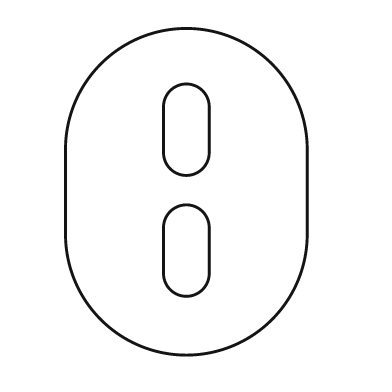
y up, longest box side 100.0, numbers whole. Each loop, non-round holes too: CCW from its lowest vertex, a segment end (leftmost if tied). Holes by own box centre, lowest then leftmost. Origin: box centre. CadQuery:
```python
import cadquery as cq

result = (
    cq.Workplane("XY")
    .moveTo(-37.0, -13.0)
    .threePointArc((0.0, -50.0), (37.0, -13.0))
    .lineTo(37.0, 13.0)
    .threePointArc((0.0, 50.0), (-37.0, 13.0))
    .close()
    .moveTo(-7.0, -25.0)
    .threePointArc((0.0, -32.0), (7.0, -25.0))
    .lineTo(7.0, -11.0)
    .threePointArc((0.0, -4.0), (-7.0, -11.0))
    .close()
    .moveTo(-7.0, 12.0)
    .threePointArc((0.0, 5.0), (7.0, 12.0))
    .lineTo(7.0, 26.0)
    .threePointArc((0.0, 33.0), (-7.0, 26.0))
    .close()
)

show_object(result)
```